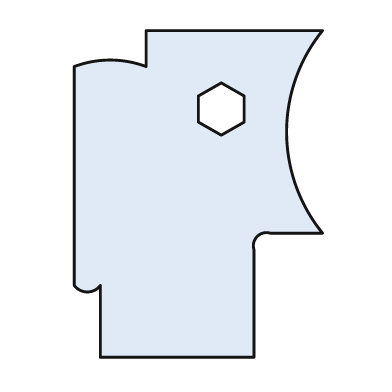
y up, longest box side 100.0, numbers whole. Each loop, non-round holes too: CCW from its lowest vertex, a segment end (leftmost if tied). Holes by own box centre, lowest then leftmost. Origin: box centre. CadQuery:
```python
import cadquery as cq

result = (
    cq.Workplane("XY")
    .moveTo(-30.0, -50.0)
    .lineTo(17.0, -50.0)
    .lineTo(17.0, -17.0)
    .threePointArc((18.0, -13.0), (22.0, -12.0))
    .lineTo(38.0, -12.0)
    .threePointArc((27.0, 19.0), (38.0, 50.0))
    .lineTo(-16.0, 50.0)
    .lineTo(-16.0, 39.0)
    .threePointArc((-27.0, 41.0), (-38.0, 39.0))
    .lineTo(-38.0, -28.0)
    .threePointArc((-34.0, -30.0), (-30.0, -28.0))
    .close()
    .moveTo(7.0, 18.0)
    .lineTo(14.0, 22.0)
    .lineTo(14.0, 30.0)
    .lineTo(7.0, 34.0)
    .lineTo(0.0, 30.0)
    .lineTo(0.0, 22.0)
    .close()
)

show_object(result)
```